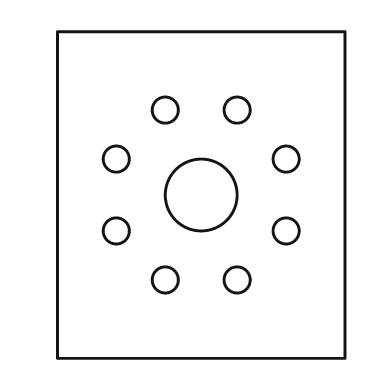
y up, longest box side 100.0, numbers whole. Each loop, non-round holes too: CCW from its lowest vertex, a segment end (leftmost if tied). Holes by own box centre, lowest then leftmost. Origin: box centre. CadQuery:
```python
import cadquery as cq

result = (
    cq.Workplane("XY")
    .moveTo(-44.0, -50.0)
    .lineTo(44.0, -50.0)
    .lineTo(44.0, 50.0)
    .lineTo(-44.0, 50.0)
    .close()
    .moveTo(-11.0, -26.0)
    .circle(4.0)
    .moveTo(11.0, -26.0)
    .circle(4.0)
    .moveTo(-26.0, -11.0)
    .circle(4.0)
    .moveTo(26.0, -11.0)
    .circle(4.0)
    .moveTo(0.0, 0.0)
    .circle(11.0)
    .moveTo(-26.0, 11.0)
    .circle(4.0)
    .moveTo(26.0, 11.0)
    .circle(4.0)
    .moveTo(-11.0, 26.0)
    .circle(4.0)
    .moveTo(11.0, 26.0)
    .circle(4.0)
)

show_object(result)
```